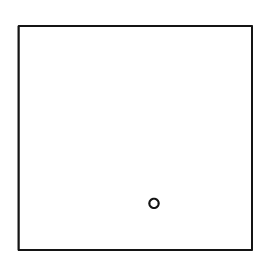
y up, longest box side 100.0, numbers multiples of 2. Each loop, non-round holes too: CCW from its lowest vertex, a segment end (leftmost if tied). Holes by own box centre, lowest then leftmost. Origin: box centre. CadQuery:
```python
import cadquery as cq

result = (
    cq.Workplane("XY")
    .moveTo(-50.0, -48.0)
    .lineTo(50.0, -48.0)
    .lineTo(50.0, 48.0)
    .lineTo(-50.0, 48.0)
    .close()
    .moveTo(8.0, -28.0)
    .circle(2.0)
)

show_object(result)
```